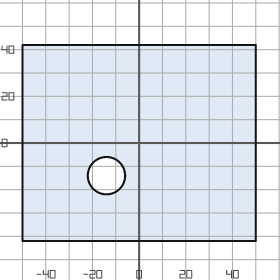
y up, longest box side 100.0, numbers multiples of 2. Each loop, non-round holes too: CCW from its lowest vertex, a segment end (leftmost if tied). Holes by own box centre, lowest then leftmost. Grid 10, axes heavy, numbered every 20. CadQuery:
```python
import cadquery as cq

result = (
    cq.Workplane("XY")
    .moveTo(-50.0, -42.0)
    .lineTo(50.0, -42.0)
    .lineTo(50.0, 42.0)
    .lineTo(-50.0, 42.0)
    .close()
    .moveTo(-14.0, -14.0)
    .circle(8.0)
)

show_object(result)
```